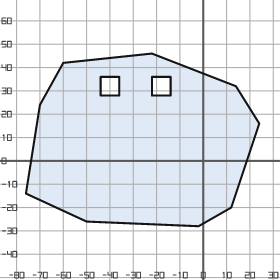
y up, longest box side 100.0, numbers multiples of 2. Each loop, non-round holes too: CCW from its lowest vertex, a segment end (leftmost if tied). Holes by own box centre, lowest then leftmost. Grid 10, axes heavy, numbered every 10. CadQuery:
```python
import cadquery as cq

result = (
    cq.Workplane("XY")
    .moveTo(-2.0, -28.0)
    .lineTo(12.0, -20.0)
    .lineTo(24.0, 16.0)
    .lineTo(14.0, 32.0)
    .lineTo(-22.0, 46.0)
    .lineTo(-60.0, 42.0)
    .lineTo(-70.0, 24.0)
    .lineTo(-76.0, -14.0)
    .lineTo(-50.0, -26.0)
    .close()
    .moveTo(-44.0, 28.0)
    .lineTo(-36.0, 28.0)
    .lineTo(-36.0, 36.0)
    .lineTo(-44.0, 36.0)
    .close()
    .moveTo(-22.0, 28.0)
    .lineTo(-14.0, 28.0)
    .lineTo(-14.0, 36.0)
    .lineTo(-22.0, 36.0)
    .close()
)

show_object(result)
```